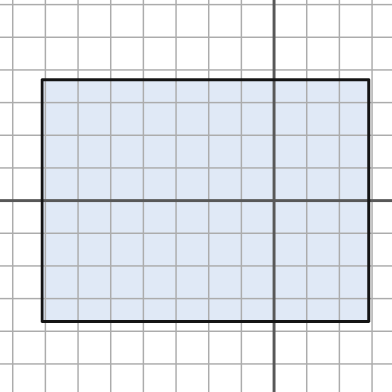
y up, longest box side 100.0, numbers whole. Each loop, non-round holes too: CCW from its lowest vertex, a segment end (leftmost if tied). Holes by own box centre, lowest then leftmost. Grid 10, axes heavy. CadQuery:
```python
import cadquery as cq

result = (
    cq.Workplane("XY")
    .moveTo(-71.0, -37.0)
    .lineTo(29.0, -37.0)
    .lineTo(29.0, 37.0)
    .lineTo(-71.0, 37.0)
    .close()
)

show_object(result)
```